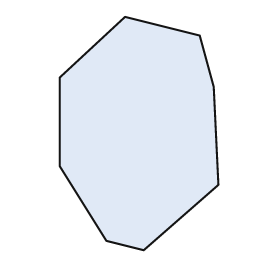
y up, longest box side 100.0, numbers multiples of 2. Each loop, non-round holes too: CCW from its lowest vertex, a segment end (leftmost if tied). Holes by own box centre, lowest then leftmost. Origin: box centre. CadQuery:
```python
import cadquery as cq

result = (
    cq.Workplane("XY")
    .moveTo(2.0, -50.0)
    .lineTo(34.0, -22.0)
    .lineTo(32.0, 20.0)
    .lineTo(26.0, 42.0)
    .lineTo(-6.0, 50.0)
    .lineTo(-34.0, 24.0)
    .lineTo(-34.0, -14.0)
    .lineTo(-14.0, -46.0)
    .close()
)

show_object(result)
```